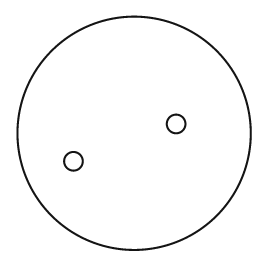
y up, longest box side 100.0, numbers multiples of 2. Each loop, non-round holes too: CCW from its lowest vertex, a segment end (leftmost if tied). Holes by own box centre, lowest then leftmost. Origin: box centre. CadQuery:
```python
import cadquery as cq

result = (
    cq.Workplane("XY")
    .moveTo(0.0, 0.0)
    .circle(50.0)
    .moveTo(-26.0, -12.0)
    .circle(4.0)
    .moveTo(18.0, 4.0)
    .circle(4.0)
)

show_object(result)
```